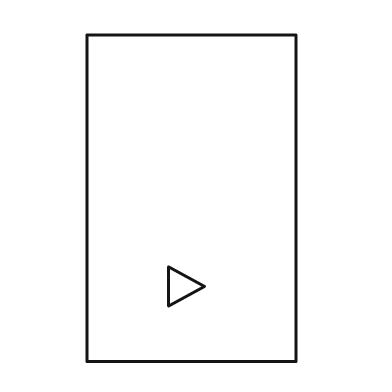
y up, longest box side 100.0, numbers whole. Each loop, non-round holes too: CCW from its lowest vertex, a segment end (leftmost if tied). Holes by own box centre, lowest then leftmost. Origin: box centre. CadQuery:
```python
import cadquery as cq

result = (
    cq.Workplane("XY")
    .moveTo(-32.0, -50.0)
    .lineTo(32.0, -50.0)
    .lineTo(32.0, 50.0)
    .lineTo(-32.0, 50.0)
    .close()
    .moveTo(-7.0, -33.0)
    .lineTo(4.0, -27.0)
    .lineTo(-7.0, -21.0)
    .close()
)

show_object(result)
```